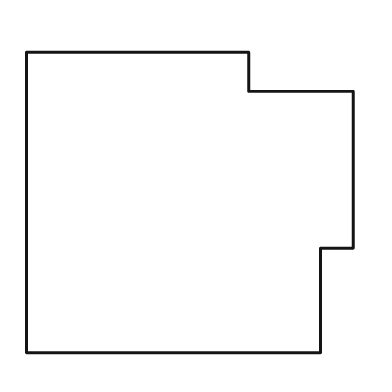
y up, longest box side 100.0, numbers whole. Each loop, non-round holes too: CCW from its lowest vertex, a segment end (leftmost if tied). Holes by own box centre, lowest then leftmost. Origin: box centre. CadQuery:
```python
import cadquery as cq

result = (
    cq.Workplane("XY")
    .moveTo(-50.0, -46.0)
    .lineTo(40.0, -46.0)
    .lineTo(40.0, -14.0)
    .lineTo(50.0, -14.0)
    .lineTo(50.0, 34.0)
    .lineTo(18.0, 34.0)
    .lineTo(18.0, 46.0)
    .lineTo(-50.0, 46.0)
    .close()
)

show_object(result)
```